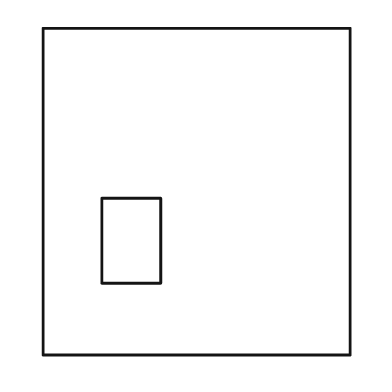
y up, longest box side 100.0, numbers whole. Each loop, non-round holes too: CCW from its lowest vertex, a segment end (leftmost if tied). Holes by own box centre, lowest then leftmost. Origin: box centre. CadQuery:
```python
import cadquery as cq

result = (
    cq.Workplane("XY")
    .moveTo(-47.0, -50.0)
    .lineTo(47.0, -50.0)
    .lineTo(47.0, 50.0)
    .lineTo(-47.0, 50.0)
    .close()
    .moveTo(-29.0, -28.0)
    .lineTo(-11.0, -28.0)
    .lineTo(-11.0, -2.0)
    .lineTo(-29.0, -2.0)
    .close()
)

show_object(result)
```